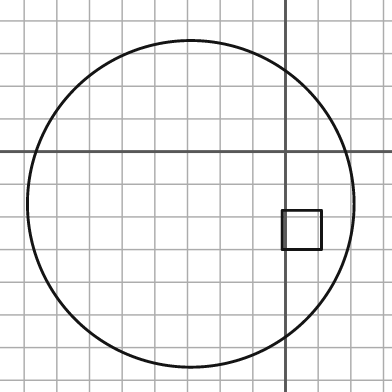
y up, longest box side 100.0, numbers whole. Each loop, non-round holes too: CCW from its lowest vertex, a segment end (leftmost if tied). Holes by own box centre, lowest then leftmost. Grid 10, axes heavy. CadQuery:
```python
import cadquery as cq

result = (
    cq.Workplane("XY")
    .moveTo(-29.0, -16.0)
    .circle(50.0)
    .moveTo(-1.0, -30.0)
    .lineTo(11.0, -30.0)
    .lineTo(11.0, -18.0)
    .lineTo(-1.0, -18.0)
    .close()
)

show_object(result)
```